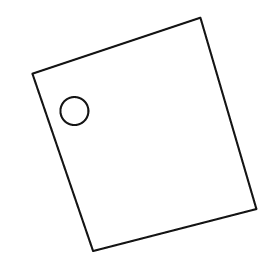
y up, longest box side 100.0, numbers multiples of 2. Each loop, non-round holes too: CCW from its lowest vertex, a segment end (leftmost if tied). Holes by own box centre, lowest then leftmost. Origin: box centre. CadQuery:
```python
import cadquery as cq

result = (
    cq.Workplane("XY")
    .moveTo(-22.0, -50.0)
    .lineTo(48.0, -32.0)
    .lineTo(24.0, 50.0)
    .lineTo(-48.0, 26.0)
    .close()
    .moveTo(-30.0, 10.0)
    .circle(6.0)
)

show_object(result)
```